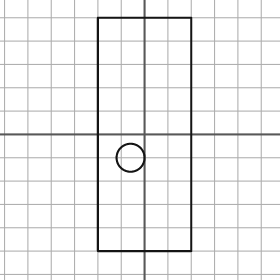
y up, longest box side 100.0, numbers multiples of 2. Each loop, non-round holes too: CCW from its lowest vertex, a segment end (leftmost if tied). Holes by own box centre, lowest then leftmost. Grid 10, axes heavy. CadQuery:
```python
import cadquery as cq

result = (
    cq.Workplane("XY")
    .moveTo(-20.0, -50.0)
    .lineTo(20.0, -50.0)
    .lineTo(20.0, 50.0)
    .lineTo(-20.0, 50.0)
    .close()
    .moveTo(-6.0, -10.0)
    .circle(6.0)
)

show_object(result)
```